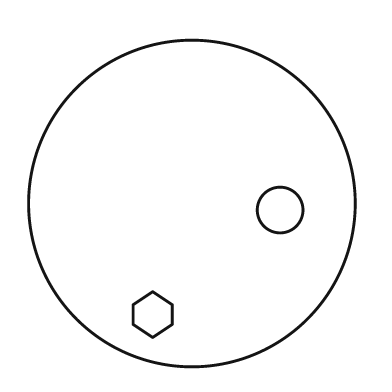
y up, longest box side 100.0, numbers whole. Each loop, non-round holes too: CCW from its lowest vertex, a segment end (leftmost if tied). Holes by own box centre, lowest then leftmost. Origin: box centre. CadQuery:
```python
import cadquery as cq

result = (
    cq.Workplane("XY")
    .moveTo(0.0, 0.0)
    .circle(50.0)
    .moveTo(-12.0, -41.0)
    .lineTo(-6.0, -37.0)
    .lineTo(-6.0, -31.0)
    .lineTo(-12.0, -27.0)
    .lineTo(-18.0, -31.0)
    .lineTo(-18.0, -37.0)
    .close()
    .moveTo(27.0, -2.0)
    .circle(7.0)
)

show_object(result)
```